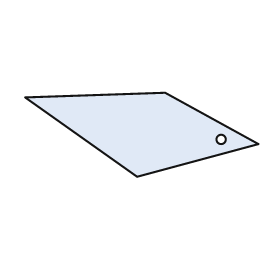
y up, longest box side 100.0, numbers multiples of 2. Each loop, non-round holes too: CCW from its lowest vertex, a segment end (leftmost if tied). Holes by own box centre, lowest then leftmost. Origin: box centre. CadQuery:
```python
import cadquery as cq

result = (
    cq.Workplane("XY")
    .moveTo(-2.0, -18.0)
    .lineTo(50.0, -4.0)
    .lineTo(10.0, 18.0)
    .lineTo(-50.0, 16.0)
    .close()
    .moveTo(34.0, -2.0)
    .circle(2.0)
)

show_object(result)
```